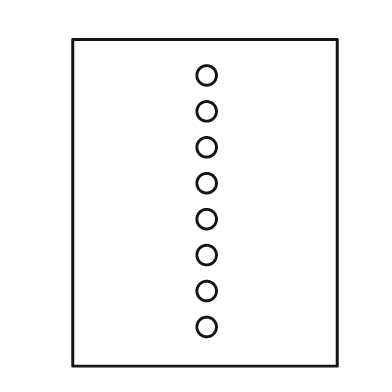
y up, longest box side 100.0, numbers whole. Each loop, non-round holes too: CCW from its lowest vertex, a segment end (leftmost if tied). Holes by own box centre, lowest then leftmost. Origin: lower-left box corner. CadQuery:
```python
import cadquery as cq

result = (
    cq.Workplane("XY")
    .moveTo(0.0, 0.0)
    .lineTo(81.0, 0.0)
    .lineTo(81.0, 100.0)
    .lineTo(0.0, 100.0)
    .close()
    .moveTo(41.0, 12.0)
    .circle(3.0)
    .moveTo(41.0, 23.0)
    .circle(3.0)
    .moveTo(41.0, 34.0)
    .circle(3.0)
    .moveTo(41.0, 45.0)
    .circle(3.0)
    .moveTo(41.0, 56.0)
    .circle(3.0)
    .moveTo(41.0, 67.0)
    .circle(3.0)
    .moveTo(41.0, 78.0)
    .circle(3.0)
    .moveTo(41.0, 89.0)
    .circle(3.0)
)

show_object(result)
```